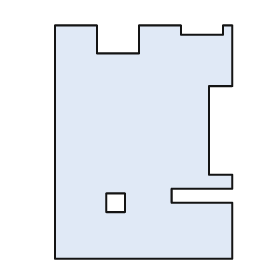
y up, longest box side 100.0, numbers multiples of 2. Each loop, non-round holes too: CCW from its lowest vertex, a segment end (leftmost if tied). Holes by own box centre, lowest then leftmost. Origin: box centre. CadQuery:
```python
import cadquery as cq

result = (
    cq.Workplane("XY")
    .moveTo(-38.0, -50.0)
    .lineTo(38.0, -50.0)
    .lineTo(38.0, -26.0)
    .lineTo(12.0, -26.0)
    .lineTo(12.0, -20.0)
    .lineTo(38.0, -20.0)
    .lineTo(38.0, -14.0)
    .lineTo(28.0, -14.0)
    .lineTo(28.0, 24.0)
    .lineTo(38.0, 24.0)
    .lineTo(38.0, 50.0)
    .lineTo(34.0, 50.0)
    .lineTo(34.0, 46.0)
    .lineTo(16.0, 46.0)
    .lineTo(16.0, 50.0)
    .lineTo(-2.0, 50.0)
    .lineTo(-2.0, 38.0)
    .lineTo(-20.0, 38.0)
    .lineTo(-20.0, 50.0)
    .lineTo(-38.0, 50.0)
    .close()
    .moveTo(-16.0, -30.0)
    .lineTo(-8.0, -30.0)
    .lineTo(-8.0, -22.0)
    .lineTo(-16.0, -22.0)
    .close()
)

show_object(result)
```